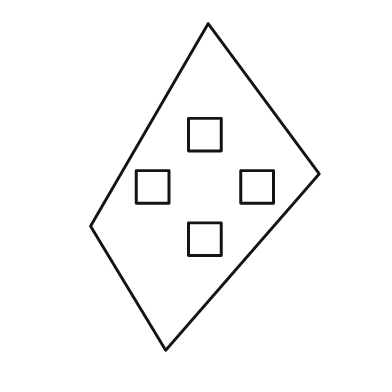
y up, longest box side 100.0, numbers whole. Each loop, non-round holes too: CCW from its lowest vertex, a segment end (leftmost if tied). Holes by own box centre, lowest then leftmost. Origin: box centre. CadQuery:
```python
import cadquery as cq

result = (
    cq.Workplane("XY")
    .moveTo(-12.0, -50.0)
    .lineTo(35.0, 4.0)
    .lineTo(1.0, 50.0)
    .lineTo(-35.0, -12.0)
    .close()
    .moveTo(-5.0, -21.0)
    .lineTo(5.0, -21.0)
    .lineTo(5.0, -11.0)
    .lineTo(-5.0, -11.0)
    .close()
    .moveTo(-21.0, -5.0)
    .lineTo(-11.0, -5.0)
    .lineTo(-11.0, 5.0)
    .lineTo(-21.0, 5.0)
    .close()
    .moveTo(11.0, -5.0)
    .lineTo(21.0, -5.0)
    .lineTo(21.0, 5.0)
    .lineTo(11.0, 5.0)
    .close()
    .moveTo(-5.0, 11.0)
    .lineTo(5.0, 11.0)
    .lineTo(5.0, 21.0)
    .lineTo(-5.0, 21.0)
    .close()
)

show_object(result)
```